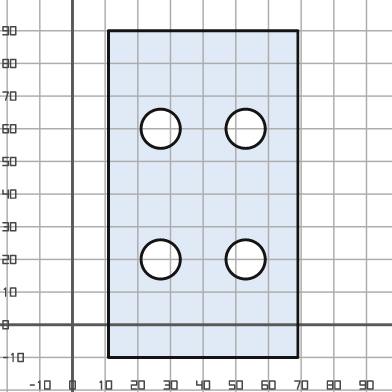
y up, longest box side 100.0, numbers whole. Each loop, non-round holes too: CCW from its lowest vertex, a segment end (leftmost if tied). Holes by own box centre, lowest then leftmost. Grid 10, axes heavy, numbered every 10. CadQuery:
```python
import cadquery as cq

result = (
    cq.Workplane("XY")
    .moveTo(11.0, -10.0)
    .lineTo(69.0, -10.0)
    .lineTo(69.0, 90.0)
    .lineTo(11.0, 90.0)
    .close()
    .moveTo(27.0, 20.0)
    .circle(6.0)
    .moveTo(53.0, 20.0)
    .circle(6.0)
    .moveTo(27.0, 60.0)
    .circle(6.0)
    .moveTo(53.0, 60.0)
    .circle(6.0)
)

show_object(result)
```